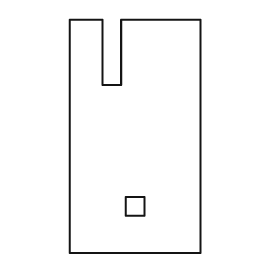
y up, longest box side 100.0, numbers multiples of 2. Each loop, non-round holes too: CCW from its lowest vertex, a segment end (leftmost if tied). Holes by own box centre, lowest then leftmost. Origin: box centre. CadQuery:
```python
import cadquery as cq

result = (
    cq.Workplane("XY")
    .moveTo(-28.0, -50.0)
    .lineTo(28.0, -50.0)
    .lineTo(28.0, 50.0)
    .lineTo(-6.0, 50.0)
    .lineTo(-6.0, 22.0)
    .lineTo(-14.0, 22.0)
    .lineTo(-14.0, 50.0)
    .lineTo(-28.0, 50.0)
    .close()
    .moveTo(-4.0, -34.0)
    .lineTo(4.0, -34.0)
    .lineTo(4.0, -26.0)
    .lineTo(-4.0, -26.0)
    .close()
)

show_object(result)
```